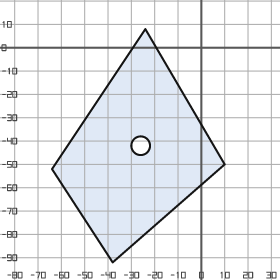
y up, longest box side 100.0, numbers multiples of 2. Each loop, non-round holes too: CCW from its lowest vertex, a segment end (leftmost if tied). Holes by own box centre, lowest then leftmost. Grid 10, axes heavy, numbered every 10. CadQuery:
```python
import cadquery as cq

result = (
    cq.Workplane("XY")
    .moveTo(-38.0, -92.0)
    .lineTo(10.0, -50.0)
    .lineTo(-24.0, 8.0)
    .lineTo(-64.0, -52.0)
    .close()
    .moveTo(-26.0, -42.0)
    .circle(4.0)
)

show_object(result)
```